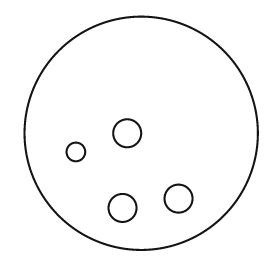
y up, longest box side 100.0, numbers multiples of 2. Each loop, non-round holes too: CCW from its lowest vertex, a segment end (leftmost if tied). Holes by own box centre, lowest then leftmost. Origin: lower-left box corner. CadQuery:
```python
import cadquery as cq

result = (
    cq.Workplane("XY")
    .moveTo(50.0, 50.0)
    .circle(50.0)
    .moveTo(42.0, 18.0)
    .circle(6.0)
    .moveTo(66.0, 22.0)
    .circle(6.0)
    .moveTo(22.0, 42.0)
    .circle(4.0)
    .moveTo(44.0, 50.0)
    .circle(6.0)
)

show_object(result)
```